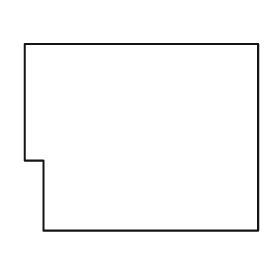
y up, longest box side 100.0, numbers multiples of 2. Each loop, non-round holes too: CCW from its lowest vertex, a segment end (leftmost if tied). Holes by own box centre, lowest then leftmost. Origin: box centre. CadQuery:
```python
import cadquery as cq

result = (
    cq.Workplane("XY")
    .moveTo(-42.0, -40.0)
    .lineTo(50.0, -40.0)
    .lineTo(50.0, 40.0)
    .lineTo(-50.0, 40.0)
    .lineTo(-50.0, -10.0)
    .lineTo(-42.0, -10.0)
    .close()
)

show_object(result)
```